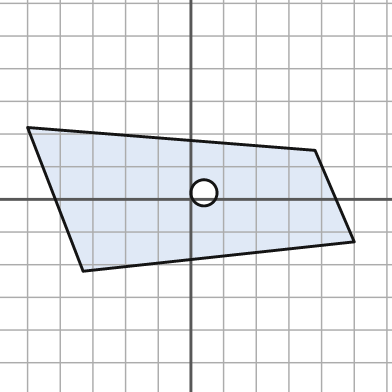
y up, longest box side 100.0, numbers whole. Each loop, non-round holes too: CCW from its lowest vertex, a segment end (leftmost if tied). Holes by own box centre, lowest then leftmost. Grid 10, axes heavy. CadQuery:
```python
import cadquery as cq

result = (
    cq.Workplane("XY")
    .moveTo(-33.0, -22.0)
    .lineTo(50.0, -13.0)
    .lineTo(38.0, 15.0)
    .lineTo(-50.0, 22.0)
    .close()
    .moveTo(4.0, 2.0)
    .circle(4.0)
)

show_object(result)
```